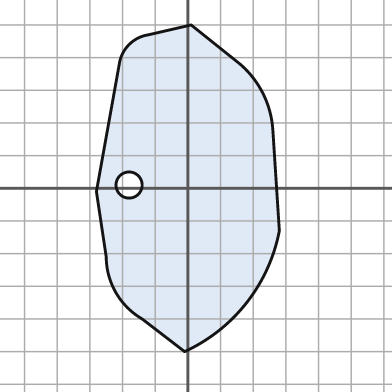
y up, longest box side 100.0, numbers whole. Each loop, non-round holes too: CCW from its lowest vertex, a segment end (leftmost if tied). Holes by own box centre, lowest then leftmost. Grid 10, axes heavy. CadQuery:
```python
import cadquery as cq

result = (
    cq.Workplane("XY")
    .moveTo(-1.0, -50.0)
    .threePointArc((18.0, -35.0), (28.0, -13.0))
    .lineTo(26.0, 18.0)
    .threePointArc((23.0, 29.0), (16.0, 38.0))
    .lineTo(1.0, 50.0)
    .lineTo(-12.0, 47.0)
    .threePointArc((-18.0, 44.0), (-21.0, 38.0))
    .lineTo(-28.0, -1.0)
    .lineTo(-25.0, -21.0)
    .threePointArc((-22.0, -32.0), (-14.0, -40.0))
    .close()
    .moveTo(-18.0, 1.0)
    .circle(4.0)
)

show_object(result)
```